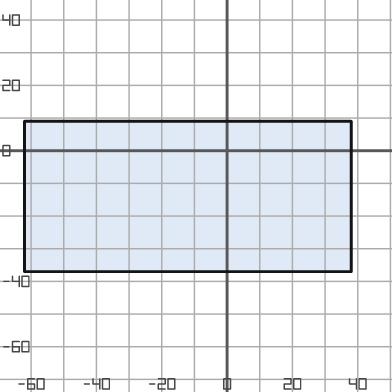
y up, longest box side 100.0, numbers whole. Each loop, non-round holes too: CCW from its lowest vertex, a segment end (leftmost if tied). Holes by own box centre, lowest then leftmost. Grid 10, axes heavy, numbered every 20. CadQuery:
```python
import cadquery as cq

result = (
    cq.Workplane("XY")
    .moveTo(-62.0, -37.0)
    .lineTo(38.0, -37.0)
    .lineTo(38.0, 9.0)
    .lineTo(-62.0, 9.0)
    .close()
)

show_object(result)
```